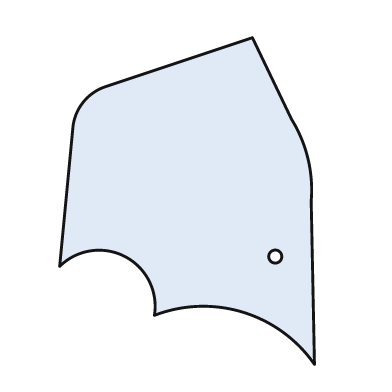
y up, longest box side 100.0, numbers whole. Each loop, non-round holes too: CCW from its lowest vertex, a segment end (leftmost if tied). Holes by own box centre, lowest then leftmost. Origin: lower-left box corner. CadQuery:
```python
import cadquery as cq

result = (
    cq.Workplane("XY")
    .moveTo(78.0, 0.0)
    .lineTo(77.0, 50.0)
    .threePointArc((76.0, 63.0), (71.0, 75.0))
    .lineTo(59.0, 100.0)
    .lineTo(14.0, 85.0)
    .threePointArc((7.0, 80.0), (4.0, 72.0))
    .lineTo(0.0, 30.0)
    .threePointArc((20.0, 33.0), (29.0, 15.0))
    .threePointArc((56.0, 16.0), (78.0, 0.0))
    .close()
    .moveTo(66.0, 33.0)
    .circle(2.0)
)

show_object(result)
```